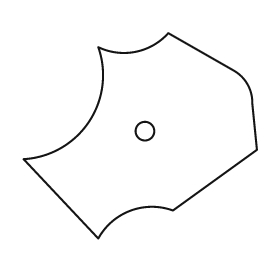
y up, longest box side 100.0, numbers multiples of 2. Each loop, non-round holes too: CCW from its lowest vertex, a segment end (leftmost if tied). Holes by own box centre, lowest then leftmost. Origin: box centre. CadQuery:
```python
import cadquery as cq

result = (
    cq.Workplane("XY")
    .moveTo(-18.0, -44.0)
    .threePointArc((-4.0, -32.0), (14.0, -32.0))
    .lineTo(50.0, -6.0)
    .lineTo(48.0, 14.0)
    .threePointArc((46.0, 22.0), (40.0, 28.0))
    .lineTo(12.0, 44.0)
    .threePointArc((-2.0, 36.0), (-18.0, 38.0))
    .threePointArc((-22.0, 6.0), (-50.0, -10.0))
    .close()
    .moveTo(2.0, 2.0)
    .circle(4.0)
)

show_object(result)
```